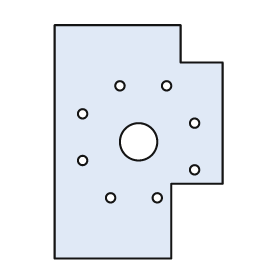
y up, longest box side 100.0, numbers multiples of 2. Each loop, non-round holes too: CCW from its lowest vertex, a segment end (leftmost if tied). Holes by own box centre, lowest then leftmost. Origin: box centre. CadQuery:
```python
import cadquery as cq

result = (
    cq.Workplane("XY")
    .moveTo(-36.0, -50.0)
    .lineTo(14.0, -50.0)
    .lineTo(14.0, -18.0)
    .lineTo(36.0, -18.0)
    .lineTo(36.0, 34.0)
    .lineTo(18.0, 34.0)
    .lineTo(18.0, 50.0)
    .lineTo(-36.0, 50.0)
    .close()
    .moveTo(-12.0, -24.0)
    .circle(2.0)
    .moveTo(8.0, -24.0)
    .circle(2.0)
    .moveTo(24.0, -12.0)
    .circle(2.0)
    .moveTo(-24.0, -8.0)
    .circle(2.0)
    .moveTo(0.0, 0.0)
    .circle(8.0)
    .moveTo(24.0, 8.0)
    .circle(2.0)
    .moveTo(-24.0, 12.0)
    .circle(2.0)
    .moveTo(-8.0, 24.0)
    .circle(2.0)
    .moveTo(12.0, 24.0)
    .circle(2.0)
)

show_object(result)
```